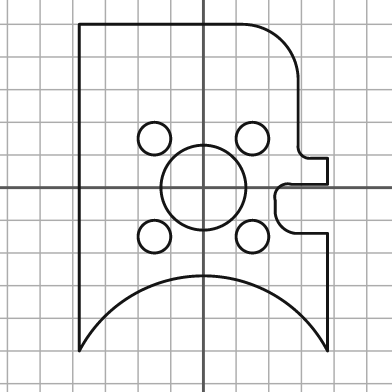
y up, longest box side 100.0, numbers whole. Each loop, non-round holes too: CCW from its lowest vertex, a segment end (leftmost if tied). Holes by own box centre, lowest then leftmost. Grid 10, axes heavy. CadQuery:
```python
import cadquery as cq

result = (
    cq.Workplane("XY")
    .moveTo(-38.0, -50.0)
    .threePointArc((0.0, -27.0), (38.0, -50.0))
    .lineTo(38.0, -14.0)
    .lineTo(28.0, -14.0)
    .threePointArc((24.0, -12.0), (22.0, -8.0))
    .lineTo(22.0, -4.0)
    .threePointArc((23.0, 0.0), (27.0, 1.0))
    .lineTo(38.0, 1.0)
    .lineTo(38.0, 9.0)
    .lineTo(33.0, 9.0)
    .threePointArc((30.0, 10.0), (29.0, 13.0))
    .lineTo(29.0, 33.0)
    .threePointArc((24.0, 45.0), (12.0, 50.0))
    .lineTo(-38.0, 50.0)
    .close()
    .moveTo(-15.0, -15.0)
    .circle(5.0)
    .moveTo(15.0, -15.0)
    .circle(5.0)
    .moveTo(0.0, 0.0)
    .circle(13.0)
    .moveTo(-15.0, 15.0)
    .circle(5.0)
    .moveTo(15.0, 15.0)
    .circle(5.0)
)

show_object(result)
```